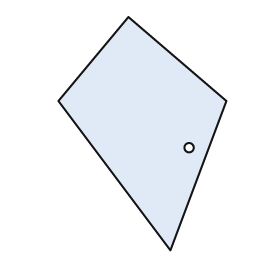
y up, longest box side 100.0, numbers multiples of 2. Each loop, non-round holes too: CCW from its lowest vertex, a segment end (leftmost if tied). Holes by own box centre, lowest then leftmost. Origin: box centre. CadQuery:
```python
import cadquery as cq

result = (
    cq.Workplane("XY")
    .moveTo(12.0, -50.0)
    .lineTo(36.0, 14.0)
    .lineTo(-6.0, 50.0)
    .lineTo(-36.0, 14.0)
    .close()
    .moveTo(20.0, -6.0)
    .circle(2.0)
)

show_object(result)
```